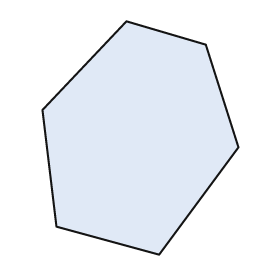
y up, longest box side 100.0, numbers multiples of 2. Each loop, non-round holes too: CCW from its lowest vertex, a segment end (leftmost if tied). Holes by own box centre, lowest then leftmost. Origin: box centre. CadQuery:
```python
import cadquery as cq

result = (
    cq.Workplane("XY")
    .moveTo(8.0, -50.0)
    .lineTo(42.0, -4.0)
    .lineTo(28.0, 40.0)
    .lineTo(-6.0, 50.0)
    .lineTo(-42.0, 12.0)
    .lineTo(-36.0, -38.0)
    .close()
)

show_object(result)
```